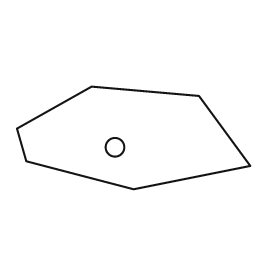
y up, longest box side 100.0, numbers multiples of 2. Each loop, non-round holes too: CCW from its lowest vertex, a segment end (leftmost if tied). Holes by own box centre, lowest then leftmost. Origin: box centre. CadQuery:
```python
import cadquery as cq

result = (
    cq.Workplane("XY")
    .moveTo(0.0, -22.0)
    .lineTo(50.0, -12.0)
    .lineTo(28.0, 18.0)
    .lineTo(-18.0, 22.0)
    .lineTo(-50.0, 4.0)
    .lineTo(-46.0, -10.0)
    .close()
    .moveTo(-8.0, -4.0)
    .circle(4.0)
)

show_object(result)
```